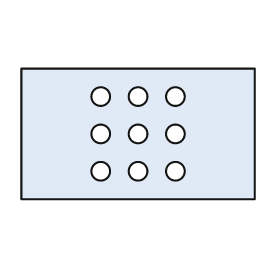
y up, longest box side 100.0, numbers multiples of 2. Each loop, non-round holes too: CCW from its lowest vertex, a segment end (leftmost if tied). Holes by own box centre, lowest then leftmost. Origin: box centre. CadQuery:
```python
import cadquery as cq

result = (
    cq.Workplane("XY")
    .moveTo(-50.0, -28.0)
    .lineTo(50.0, -28.0)
    .lineTo(50.0, 28.0)
    .lineTo(-50.0, 28.0)
    .close()
    .moveTo(-16.0, -16.0)
    .circle(4.0)
    .moveTo(0.0, -16.0)
    .circle(4.0)
    .moveTo(16.0, -16.0)
    .circle(4.0)
    .moveTo(-16.0, 0.0)
    .circle(4.0)
    .moveTo(0.0, 0.0)
    .circle(4.0)
    .moveTo(16.0, 0.0)
    .circle(4.0)
    .moveTo(-16.0, 16.0)
    .circle(4.0)
    .moveTo(0.0, 16.0)
    .circle(4.0)
    .moveTo(16.0, 16.0)
    .circle(4.0)
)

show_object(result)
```